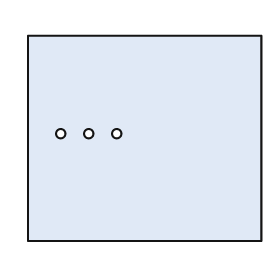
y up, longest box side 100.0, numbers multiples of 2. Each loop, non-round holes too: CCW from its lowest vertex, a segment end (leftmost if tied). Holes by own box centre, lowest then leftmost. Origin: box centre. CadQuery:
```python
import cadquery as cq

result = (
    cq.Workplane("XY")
    .moveTo(-50.0, -44.0)
    .lineTo(50.0, -44.0)
    .lineTo(50.0, 44.0)
    .lineTo(-50.0, 44.0)
    .close()
    .moveTo(-36.0, 2.0)
    .circle(2.0)
    .moveTo(-24.0, 2.0)
    .circle(2.0)
    .moveTo(-12.0, 2.0)
    .circle(2.0)
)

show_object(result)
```